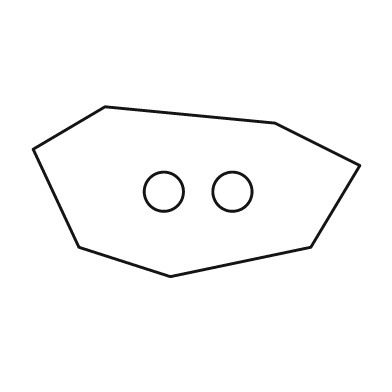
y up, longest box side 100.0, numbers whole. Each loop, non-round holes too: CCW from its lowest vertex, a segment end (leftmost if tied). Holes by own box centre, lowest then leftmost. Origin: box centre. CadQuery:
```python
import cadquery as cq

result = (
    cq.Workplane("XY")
    .moveTo(-8.0, -26.0)
    .lineTo(35.0, -17.0)
    .lineTo(50.0, 8.0)
    .lineTo(24.0, 21.0)
    .lineTo(-28.0, 26.0)
    .lineTo(-50.0, 13.0)
    .lineTo(-36.0, -17.0)
    .close()
    .moveTo(-10.0, 0.0)
    .circle(6.0)
    .moveTo(11.0, 0.0)
    .circle(6.0)
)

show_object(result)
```